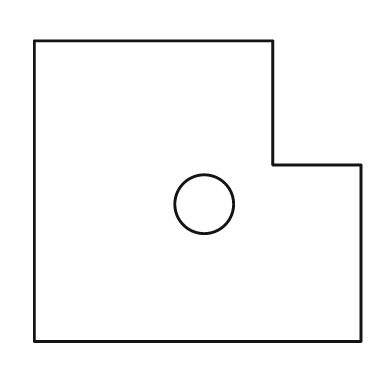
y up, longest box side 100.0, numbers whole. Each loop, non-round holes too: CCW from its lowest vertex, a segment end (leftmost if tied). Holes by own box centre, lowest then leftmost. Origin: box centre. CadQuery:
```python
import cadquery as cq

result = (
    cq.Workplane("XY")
    .moveTo(-50.0, -46.0)
    .lineTo(50.0, -46.0)
    .lineTo(50.0, 8.0)
    .lineTo(23.0, 8.0)
    .lineTo(23.0, 46.0)
    .lineTo(-50.0, 46.0)
    .close()
    .moveTo(2.0, -4.0)
    .circle(9.0)
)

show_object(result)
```